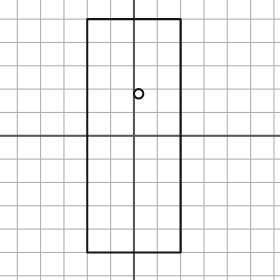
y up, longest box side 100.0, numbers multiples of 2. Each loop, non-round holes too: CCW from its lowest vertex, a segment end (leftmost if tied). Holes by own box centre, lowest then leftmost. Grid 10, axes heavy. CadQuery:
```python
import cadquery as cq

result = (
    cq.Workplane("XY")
    .moveTo(-20.0, -50.0)
    .lineTo(20.0, -50.0)
    .lineTo(20.0, 50.0)
    .lineTo(-20.0, 50.0)
    .close()
    .moveTo(2.0, 18.0)
    .circle(2.0)
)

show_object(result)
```